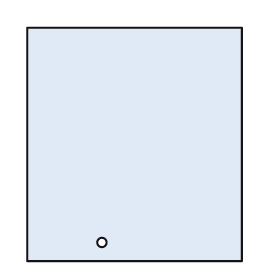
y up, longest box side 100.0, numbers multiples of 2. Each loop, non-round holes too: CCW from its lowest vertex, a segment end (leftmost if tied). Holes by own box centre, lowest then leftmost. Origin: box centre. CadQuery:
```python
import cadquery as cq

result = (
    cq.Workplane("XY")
    .moveTo(-46.0, -50.0)
    .lineTo(46.0, -50.0)
    .lineTo(46.0, 50.0)
    .lineTo(-46.0, 50.0)
    .close()
    .moveTo(-14.0, -42.0)
    .circle(2.0)
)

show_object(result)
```